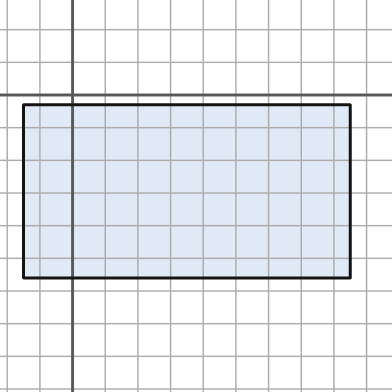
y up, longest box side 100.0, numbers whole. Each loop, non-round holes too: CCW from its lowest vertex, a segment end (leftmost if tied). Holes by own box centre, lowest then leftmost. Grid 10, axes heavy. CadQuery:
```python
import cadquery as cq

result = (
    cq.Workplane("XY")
    .moveTo(-15.0, -56.0)
    .lineTo(85.0, -56.0)
    .lineTo(85.0, -3.0)
    .lineTo(-15.0, -3.0)
    .close()
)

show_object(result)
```